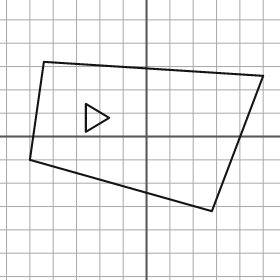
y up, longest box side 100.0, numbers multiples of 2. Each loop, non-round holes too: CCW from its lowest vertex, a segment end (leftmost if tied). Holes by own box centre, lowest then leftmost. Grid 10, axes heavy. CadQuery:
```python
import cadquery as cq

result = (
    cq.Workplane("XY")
    .moveTo(28.0, -32.0)
    .lineTo(50.0, 26.0)
    .lineTo(-44.0, 32.0)
    .lineTo(-50.0, -10.0)
    .close()
    .moveTo(-26.0, 2.0)
    .lineTo(-16.0, 8.0)
    .lineTo(-26.0, 14.0)
    .close()
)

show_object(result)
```